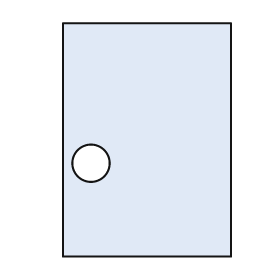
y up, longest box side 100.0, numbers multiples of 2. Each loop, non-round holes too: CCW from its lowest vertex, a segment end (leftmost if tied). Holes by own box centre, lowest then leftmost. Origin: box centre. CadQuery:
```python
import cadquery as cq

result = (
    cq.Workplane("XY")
    .moveTo(-36.0, -50.0)
    .lineTo(36.0, -50.0)
    .lineTo(36.0, 50.0)
    .lineTo(-36.0, 50.0)
    .close()
    .moveTo(-24.0, -10.0)
    .circle(8.0)
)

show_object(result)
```